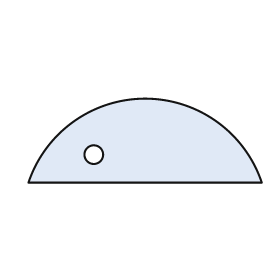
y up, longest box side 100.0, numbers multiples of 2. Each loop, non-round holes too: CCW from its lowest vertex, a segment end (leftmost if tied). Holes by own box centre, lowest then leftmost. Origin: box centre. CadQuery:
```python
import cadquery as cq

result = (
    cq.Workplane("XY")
    .moveTo(-50.0, -18.0)
    .lineTo(50.0, -18.0)
    .threePointArc((0.0, 18.0), (-50.0, -18.0))
    .close()
    .moveTo(-22.0, -6.0)
    .circle(4.0)
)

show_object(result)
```